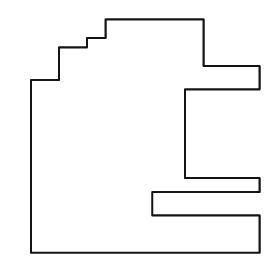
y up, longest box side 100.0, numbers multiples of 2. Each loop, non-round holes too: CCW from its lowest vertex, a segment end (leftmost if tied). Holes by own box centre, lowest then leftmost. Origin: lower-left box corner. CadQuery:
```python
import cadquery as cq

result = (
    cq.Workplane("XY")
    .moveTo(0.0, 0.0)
    .lineTo(98.0, 0.0)
    .lineTo(98.0, 16.0)
    .lineTo(52.0, 16.0)
    .lineTo(52.0, 26.0)
    .lineTo(98.0, 26.0)
    .lineTo(98.0, 32.0)
    .lineTo(66.0, 32.0)
    .lineTo(66.0, 70.0)
    .lineTo(98.0, 70.0)
    .lineTo(98.0, 80.0)
    .lineTo(74.0, 80.0)
    .lineTo(74.0, 100.0)
    .lineTo(32.0, 100.0)
    .lineTo(32.0, 92.0)
    .lineTo(24.0, 92.0)
    .lineTo(24.0, 88.0)
    .lineTo(12.0, 88.0)
    .lineTo(12.0, 74.0)
    .lineTo(0.0, 74.0)
    .close()
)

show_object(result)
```